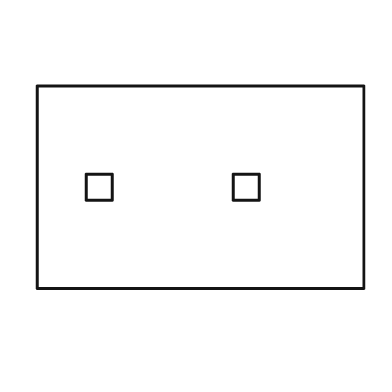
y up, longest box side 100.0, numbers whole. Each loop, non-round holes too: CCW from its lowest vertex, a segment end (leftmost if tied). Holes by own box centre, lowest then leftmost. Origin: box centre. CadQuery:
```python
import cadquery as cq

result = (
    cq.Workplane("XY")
    .moveTo(-50.0, -31.0)
    .lineTo(50.0, -31.0)
    .lineTo(50.0, 31.0)
    .lineTo(-50.0, 31.0)
    .close()
    .moveTo(-35.0, -4.0)
    .lineTo(-27.0, -4.0)
    .lineTo(-27.0, 4.0)
    .lineTo(-35.0, 4.0)
    .close()
    .moveTo(10.0, -4.0)
    .lineTo(18.0, -4.0)
    .lineTo(18.0, 4.0)
    .lineTo(10.0, 4.0)
    .close()
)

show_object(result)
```